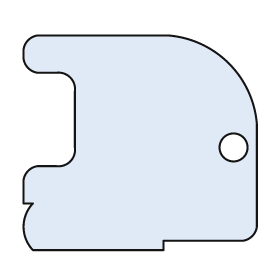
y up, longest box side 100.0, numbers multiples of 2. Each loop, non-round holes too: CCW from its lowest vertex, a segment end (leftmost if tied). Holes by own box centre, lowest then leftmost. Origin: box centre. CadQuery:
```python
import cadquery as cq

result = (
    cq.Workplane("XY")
    .moveTo(-46.0, -46.0)
    .lineTo(10.0, -46.0)
    .lineTo(10.0, -42.0)
    .lineTo(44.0, -42.0)
    .threePointArc((48.0, -40.0), (50.0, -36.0))
    .lineTo(50.0, 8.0)
    .threePointArc((38.0, 34.0), (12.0, 46.0))
    .lineTo(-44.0, 46.0)
    .threePointArc((-48.0, 44.0), (-50.0, 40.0))
    .lineTo(-50.0, 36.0)
    .threePointArc((-48.0, 32.0), (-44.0, 30.0))
    .lineTo(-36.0, 30.0)
    .threePointArc((-30.0, 28.0), (-28.0, 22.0))
    .lineTo(-28.0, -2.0)
    .threePointArc((-30.0, -8.0), (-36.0, -10.0))
    .lineTo(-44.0, -10.0)
    .threePointArc((-48.0, -12.0), (-50.0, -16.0))
    .lineTo(-50.0, -26.0)
    .lineTo(-46.0, -26.0)
    .threePointArc((-50.0, -36.0), (-46.0, -46.0))
    .close()
    .moveTo(40.0, -2.0)
    .circle(6.0)
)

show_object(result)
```